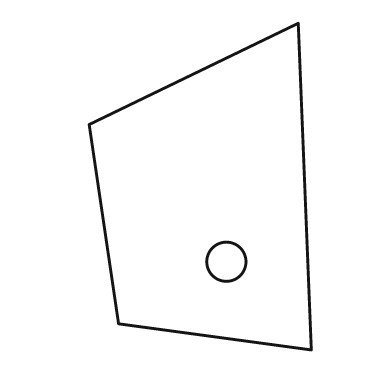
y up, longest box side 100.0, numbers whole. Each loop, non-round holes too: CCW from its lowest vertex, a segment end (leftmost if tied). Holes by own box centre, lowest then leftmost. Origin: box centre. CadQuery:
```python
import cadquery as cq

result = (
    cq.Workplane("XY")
    .moveTo(34.0, -50.0)
    .lineTo(30.0, 50.0)
    .lineTo(-34.0, 19.0)
    .lineTo(-25.0, -42.0)
    .close()
    .moveTo(8.0, -23.0)
    .circle(6.0)
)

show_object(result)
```